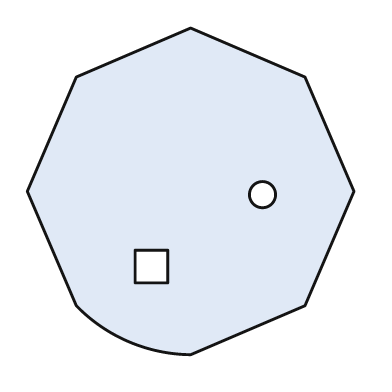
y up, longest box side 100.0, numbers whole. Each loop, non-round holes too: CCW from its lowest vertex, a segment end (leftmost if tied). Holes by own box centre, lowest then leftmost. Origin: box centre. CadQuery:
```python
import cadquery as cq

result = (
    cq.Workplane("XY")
    .moveTo(0.0, -50.0)
    .lineTo(35.0, -35.0)
    .lineTo(50.0, 0.0)
    .lineTo(35.0, 35.0)
    .lineTo(0.0, 50.0)
    .lineTo(-35.0, 35.0)
    .lineTo(-50.0, 0.0)
    .lineTo(-35.0, -35.0)
    .threePointArc((-19.0, -46.0), (0.0, -50.0))
    .close()
    .moveTo(-17.0, -28.0)
    .lineTo(-7.0, -28.0)
    .lineTo(-7.0, -18.0)
    .lineTo(-17.0, -18.0)
    .close()
    .moveTo(22.0, -1.0)
    .circle(4.0)
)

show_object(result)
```